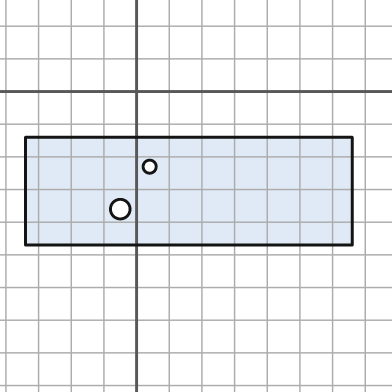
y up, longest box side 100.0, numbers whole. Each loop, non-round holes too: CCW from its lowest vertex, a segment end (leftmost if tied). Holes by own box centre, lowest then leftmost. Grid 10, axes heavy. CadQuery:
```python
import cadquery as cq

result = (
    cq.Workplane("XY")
    .moveTo(-34.0, -47.0)
    .lineTo(66.0, -47.0)
    .lineTo(66.0, -14.0)
    .lineTo(-34.0, -14.0)
    .close()
    .moveTo(-5.0, -36.0)
    .circle(3.0)
    .moveTo(4.0, -23.0)
    .circle(2.0)
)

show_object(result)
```